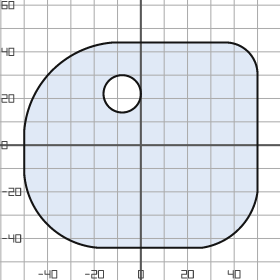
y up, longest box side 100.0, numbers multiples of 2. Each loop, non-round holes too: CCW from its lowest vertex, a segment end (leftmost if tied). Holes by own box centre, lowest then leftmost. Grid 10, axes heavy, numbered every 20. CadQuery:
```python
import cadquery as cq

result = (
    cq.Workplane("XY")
    .moveTo(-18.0, -44.0)
    .lineTo(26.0, -44.0)
    .threePointArc((42.0, -36.0), (50.0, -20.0))
    .lineTo(50.0, 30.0)
    .threePointArc((46.0, 40.0), (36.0, 44.0))
    .lineTo(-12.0, 44.0)
    .threePointArc((-38.0, 32.0), (-50.0, 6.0))
    .lineTo(-50.0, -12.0)
    .threePointArc((-40.0, -34.0), (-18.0, -44.0))
    .close()
    .moveTo(-8.0, 22.0)
    .circle(8.0)
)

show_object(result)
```